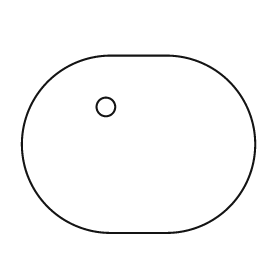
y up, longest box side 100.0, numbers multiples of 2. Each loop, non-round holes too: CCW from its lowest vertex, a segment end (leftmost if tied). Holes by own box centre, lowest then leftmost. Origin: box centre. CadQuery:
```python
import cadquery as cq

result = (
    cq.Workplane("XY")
    .moveTo(-12.0, -38.0)
    .lineTo(12.0, -38.0)
    .threePointArc((50.0, 0.0), (12.0, 38.0))
    .lineTo(-12.0, 38.0)
    .threePointArc((-50.0, 0.0), (-12.0, -38.0))
    .close()
    .moveTo(-14.0, 16.0)
    .circle(4.0)
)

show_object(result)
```